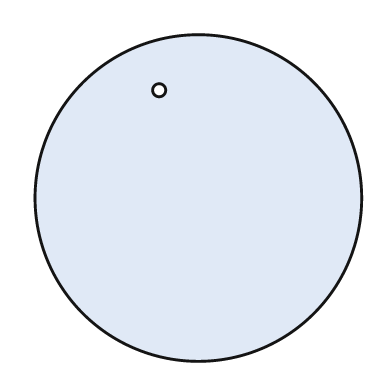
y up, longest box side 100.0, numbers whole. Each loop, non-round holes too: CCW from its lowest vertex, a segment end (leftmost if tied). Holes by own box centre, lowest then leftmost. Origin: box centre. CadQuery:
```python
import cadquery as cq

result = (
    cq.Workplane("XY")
    .moveTo(0.0, 0.0)
    .circle(50.0)
    .moveTo(-12.0, 33.0)
    .circle(2.0)
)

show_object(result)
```